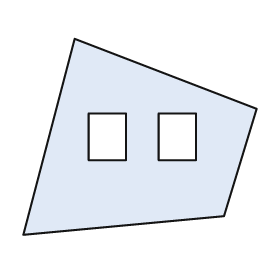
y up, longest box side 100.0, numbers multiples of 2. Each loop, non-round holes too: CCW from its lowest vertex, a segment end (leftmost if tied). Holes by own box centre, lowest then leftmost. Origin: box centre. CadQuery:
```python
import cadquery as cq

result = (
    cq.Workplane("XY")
    .moveTo(-50.0, -42.0)
    .lineTo(36.0, -34.0)
    .lineTo(50.0, 12.0)
    .lineTo(-28.0, 42.0)
    .close()
    .moveTo(-22.0, -10.0)
    .lineTo(-6.0, -10.0)
    .lineTo(-6.0, 10.0)
    .lineTo(-22.0, 10.0)
    .close()
    .moveTo(8.0, -10.0)
    .lineTo(24.0, -10.0)
    .lineTo(24.0, 10.0)
    .lineTo(8.0, 10.0)
    .close()
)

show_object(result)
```